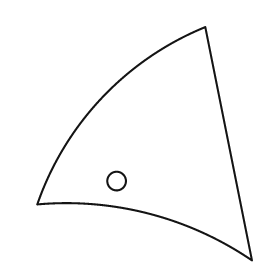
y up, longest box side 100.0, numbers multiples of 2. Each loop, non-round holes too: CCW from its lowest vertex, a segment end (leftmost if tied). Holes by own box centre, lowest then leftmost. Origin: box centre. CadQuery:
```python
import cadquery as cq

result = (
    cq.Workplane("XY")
    .moveTo(46.0, -50.0)
    .lineTo(26.0, 50.0)
    .threePointArc((-18.0, 20.0), (-46.0, -26.0))
    .threePointArc((2.0, -30.0), (46.0, -50.0))
    .close()
    .moveTo(-12.0, -16.0)
    .circle(4.0)
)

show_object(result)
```